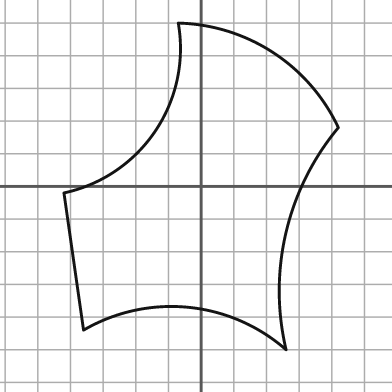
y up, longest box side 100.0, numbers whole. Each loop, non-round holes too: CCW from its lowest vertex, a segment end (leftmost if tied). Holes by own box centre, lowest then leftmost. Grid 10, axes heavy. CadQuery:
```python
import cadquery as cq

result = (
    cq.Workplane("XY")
    .moveTo(26.0, -50.0)
    .threePointArc((26.0, -14.0), (42.0, 18.0))
    .threePointArc((22.0, 41.0), (-7.0, 50.0))
    .threePointArc((-14.0, 17.0), (-42.0, -2.0))
    .lineTo(-36.0, -44.0)
    .threePointArc((-4.0, -37.0), (26.0, -50.0))
    .close()
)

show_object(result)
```